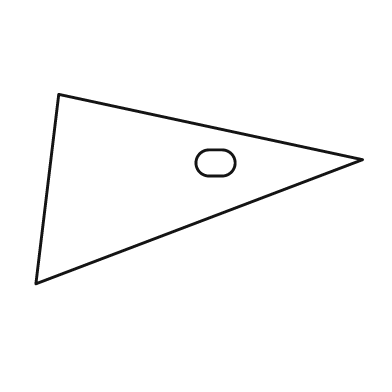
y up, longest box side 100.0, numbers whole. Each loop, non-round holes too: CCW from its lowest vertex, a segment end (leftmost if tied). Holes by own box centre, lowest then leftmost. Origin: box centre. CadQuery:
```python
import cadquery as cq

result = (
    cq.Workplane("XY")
    .moveTo(-50.0, -29.0)
    .lineTo(50.0, 9.0)
    .lineTo(-43.0, 29.0)
    .close()
    .moveTo(3.0, 4.0)
    .lineTo(7.0, 4.0)
    .threePointArc((11.0, 8.0), (7.0, 12.0))
    .lineTo(3.0, 12.0)
    .threePointArc((-1.0, 8.0), (3.0, 4.0))
    .close()
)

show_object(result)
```